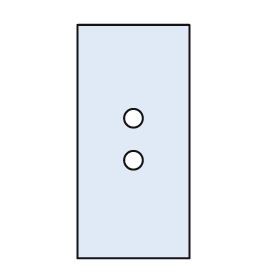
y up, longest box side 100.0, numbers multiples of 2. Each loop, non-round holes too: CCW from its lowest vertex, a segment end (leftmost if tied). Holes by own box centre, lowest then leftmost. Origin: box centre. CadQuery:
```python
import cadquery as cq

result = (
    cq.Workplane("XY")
    .moveTo(-24.0, -50.0)
    .lineTo(24.0, -50.0)
    .lineTo(24.0, 50.0)
    .lineTo(-24.0, 50.0)
    .close()
    .moveTo(0.0, -8.0)
    .circle(4.0)
    .moveTo(0.0, 10.0)
    .circle(4.0)
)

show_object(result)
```